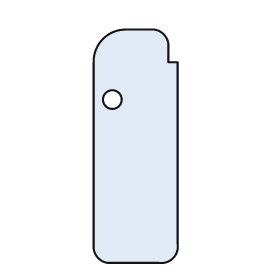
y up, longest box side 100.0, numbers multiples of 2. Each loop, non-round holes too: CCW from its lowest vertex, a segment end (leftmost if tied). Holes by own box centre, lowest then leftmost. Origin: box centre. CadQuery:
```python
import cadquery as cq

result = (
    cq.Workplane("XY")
    .moveTo(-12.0, -50.0)
    .lineTo(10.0, -50.0)
    .threePointArc((16.0, -48.0), (18.0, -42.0))
    .lineTo(18.0, 36.0)
    .lineTo(14.0, 36.0)
    .lineTo(14.0, 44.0)
    .threePointArc((12.0, 48.0), (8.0, 50.0))
    .lineTo(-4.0, 50.0)
    .threePointArc((-14.0, 46.0), (-18.0, 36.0))
    .lineTo(-18.0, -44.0)
    .threePointArc((-16.0, -48.0), (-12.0, -50.0))
    .close()
    .moveTo(-10.0, 20.0)
    .circle(4.0)
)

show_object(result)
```